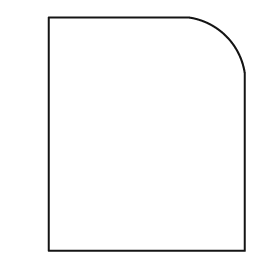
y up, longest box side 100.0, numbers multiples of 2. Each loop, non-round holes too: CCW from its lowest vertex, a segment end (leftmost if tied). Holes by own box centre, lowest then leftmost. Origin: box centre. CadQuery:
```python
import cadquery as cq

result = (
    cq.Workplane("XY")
    .moveTo(-42.0, -50.0)
    .lineTo(42.0, -50.0)
    .lineTo(42.0, 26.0)
    .threePointArc((34.0, 42.0), (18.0, 50.0))
    .lineTo(-42.0, 50.0)
    .close()
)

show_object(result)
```